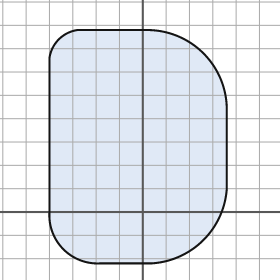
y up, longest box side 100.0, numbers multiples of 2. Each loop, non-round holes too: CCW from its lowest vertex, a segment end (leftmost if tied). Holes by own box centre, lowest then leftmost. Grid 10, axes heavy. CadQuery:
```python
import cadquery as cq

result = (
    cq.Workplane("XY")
    .moveTo(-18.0, -22.0)
    .lineTo(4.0, -22.0)
    .threePointArc((26.0, -12.0), (36.0, 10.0))
    .lineTo(36.0, 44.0)
    .threePointArc((26.0, 68.0), (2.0, 78.0))
    .lineTo(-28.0, 78.0)
    .threePointArc((-36.0, 74.0), (-40.0, 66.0))
    .lineTo(-40.0, 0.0)
    .threePointArc((-34.0, -16.0), (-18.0, -22.0))
    .close()
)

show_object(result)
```